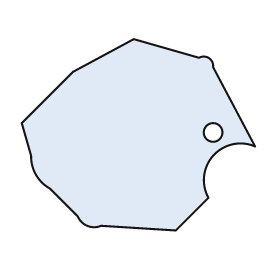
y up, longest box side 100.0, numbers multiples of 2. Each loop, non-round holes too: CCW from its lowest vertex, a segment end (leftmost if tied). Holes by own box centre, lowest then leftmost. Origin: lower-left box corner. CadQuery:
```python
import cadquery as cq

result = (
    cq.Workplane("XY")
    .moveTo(66.0, 0.0)
    .lineTo(80.0, 14.0)
    .threePointArc((82.0, 32.0), (100.0, 36.0))
    .lineTo(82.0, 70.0)
    .threePointArc((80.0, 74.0), (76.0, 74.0))
    .lineTo(48.0, 82.0)
    .lineTo(22.0, 68.0)
    .lineTo(0.0, 46.0)
    .lineTo(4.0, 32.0)
    .threePointArc((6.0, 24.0), (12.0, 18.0))
    .lineTo(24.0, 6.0)
    .threePointArc((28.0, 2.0), (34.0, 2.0))
    .close()
    .moveTo(82.0, 42.0)
    .circle(4.0)
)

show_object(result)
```